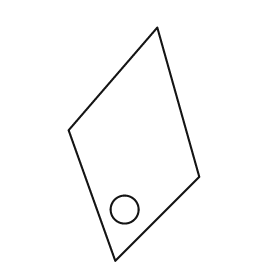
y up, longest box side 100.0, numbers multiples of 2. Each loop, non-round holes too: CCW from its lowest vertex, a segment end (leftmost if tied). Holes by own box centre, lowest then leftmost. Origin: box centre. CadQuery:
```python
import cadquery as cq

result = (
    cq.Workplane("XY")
    .moveTo(-8.0, -50.0)
    .lineTo(28.0, -14.0)
    .lineTo(10.0, 50.0)
    .lineTo(-28.0, 6.0)
    .close()
    .moveTo(-4.0, -28.0)
    .circle(6.0)
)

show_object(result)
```